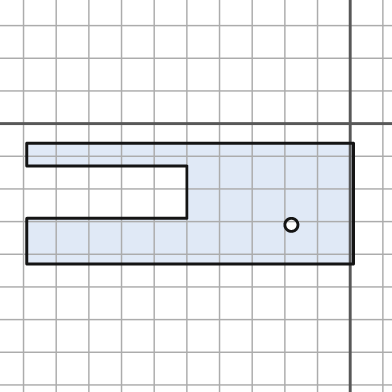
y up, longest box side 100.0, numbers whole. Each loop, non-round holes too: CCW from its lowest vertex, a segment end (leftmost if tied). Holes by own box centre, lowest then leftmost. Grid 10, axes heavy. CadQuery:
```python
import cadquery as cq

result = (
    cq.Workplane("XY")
    .moveTo(-99.0, -43.0)
    .lineTo(1.0, -43.0)
    .lineTo(1.0, -6.0)
    .lineTo(-99.0, -6.0)
    .lineTo(-99.0, -13.0)
    .lineTo(-50.0, -13.0)
    .lineTo(-50.0, -29.0)
    .lineTo(-99.0, -29.0)
    .close()
    .moveTo(-18.0, -31.0)
    .circle(2.0)
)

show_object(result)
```